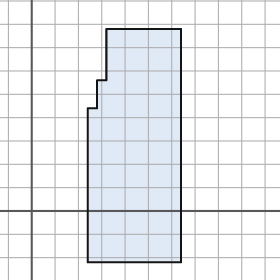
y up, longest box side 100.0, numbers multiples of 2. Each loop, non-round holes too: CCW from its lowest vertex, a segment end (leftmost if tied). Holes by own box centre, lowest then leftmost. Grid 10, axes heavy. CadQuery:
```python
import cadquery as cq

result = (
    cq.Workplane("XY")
    .moveTo(24.0, -22.0)
    .lineTo(64.0, -22.0)
    .lineTo(64.0, 78.0)
    .lineTo(32.0, 78.0)
    .lineTo(32.0, 56.0)
    .lineTo(28.0, 56.0)
    .lineTo(28.0, 44.0)
    .lineTo(24.0, 44.0)
    .close()
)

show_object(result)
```